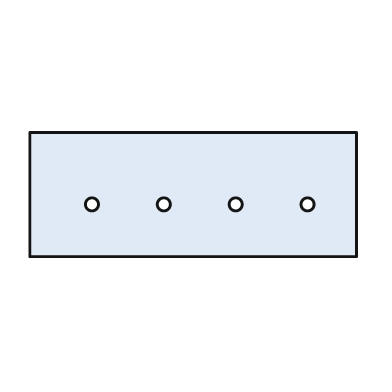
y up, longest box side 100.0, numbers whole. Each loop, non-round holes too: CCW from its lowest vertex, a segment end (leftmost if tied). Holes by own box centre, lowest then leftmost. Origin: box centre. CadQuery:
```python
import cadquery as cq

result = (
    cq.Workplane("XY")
    .moveTo(-50.0, -19.0)
    .lineTo(50.0, -19.0)
    .lineTo(50.0, 19.0)
    .lineTo(-50.0, 19.0)
    .close()
    .moveTo(-31.0, -3.0)
    .circle(2.0)
    .moveTo(-9.0, -3.0)
    .circle(2.0)
    .moveTo(13.0, -3.0)
    .circle(2.0)
    .moveTo(35.0, -3.0)
    .circle(2.0)
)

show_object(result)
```